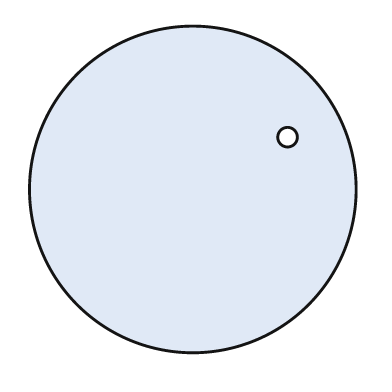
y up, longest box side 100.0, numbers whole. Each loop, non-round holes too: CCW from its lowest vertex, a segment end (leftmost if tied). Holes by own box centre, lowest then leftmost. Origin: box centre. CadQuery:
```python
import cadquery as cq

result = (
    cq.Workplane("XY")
    .moveTo(0.0, 0.0)
    .circle(50.0)
    .moveTo(29.0, 16.0)
    .circle(3.0)
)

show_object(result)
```